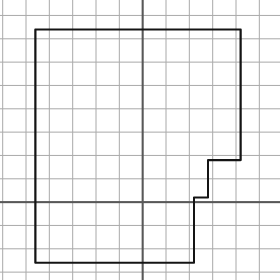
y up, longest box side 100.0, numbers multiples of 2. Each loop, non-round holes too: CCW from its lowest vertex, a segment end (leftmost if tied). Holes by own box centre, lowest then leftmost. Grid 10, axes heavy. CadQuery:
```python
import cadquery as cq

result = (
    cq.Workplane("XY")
    .moveTo(-46.0, -26.0)
    .lineTo(22.0, -26.0)
    .lineTo(22.0, 2.0)
    .lineTo(28.0, 2.0)
    .lineTo(28.0, 18.0)
    .lineTo(42.0, 18.0)
    .lineTo(42.0, 74.0)
    .lineTo(-46.0, 74.0)
    .close()
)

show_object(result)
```